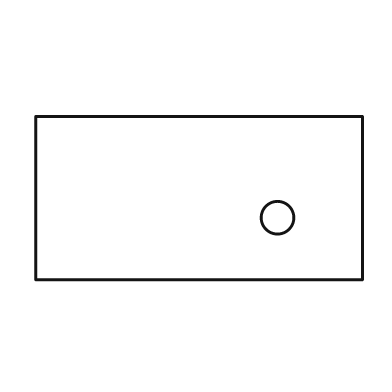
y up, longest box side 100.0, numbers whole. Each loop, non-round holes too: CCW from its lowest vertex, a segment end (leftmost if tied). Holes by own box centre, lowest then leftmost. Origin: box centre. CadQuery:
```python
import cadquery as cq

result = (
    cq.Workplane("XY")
    .moveTo(-50.0, -25.0)
    .lineTo(50.0, -25.0)
    .lineTo(50.0, 25.0)
    .lineTo(-50.0, 25.0)
    .close()
    .moveTo(24.0, -6.0)
    .circle(5.0)
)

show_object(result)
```